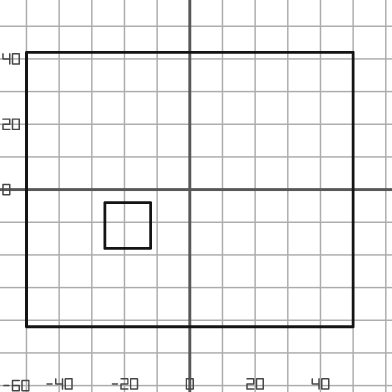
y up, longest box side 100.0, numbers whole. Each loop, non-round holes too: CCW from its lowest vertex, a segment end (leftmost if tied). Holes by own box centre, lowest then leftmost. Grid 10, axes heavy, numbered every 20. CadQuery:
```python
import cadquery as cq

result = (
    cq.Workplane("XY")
    .moveTo(-50.0, -42.0)
    .lineTo(50.0, -42.0)
    .lineTo(50.0, 42.0)
    .lineTo(-50.0, 42.0)
    .close()
    .moveTo(-26.0, -18.0)
    .lineTo(-12.0, -18.0)
    .lineTo(-12.0, -4.0)
    .lineTo(-26.0, -4.0)
    .close()
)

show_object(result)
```